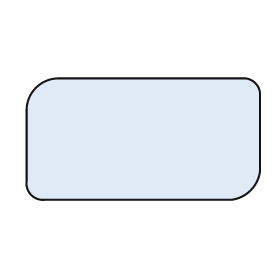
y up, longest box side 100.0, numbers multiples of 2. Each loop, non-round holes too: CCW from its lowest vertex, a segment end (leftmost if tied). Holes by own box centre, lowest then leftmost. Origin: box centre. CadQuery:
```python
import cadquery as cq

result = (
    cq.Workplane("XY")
    .moveTo(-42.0, -26.0)
    .lineTo(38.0, -26.0)
    .threePointArc((46.0, -22.0), (50.0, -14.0))
    .lineTo(50.0, 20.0)
    .threePointArc((48.0, 24.0), (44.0, 26.0))
    .lineTo(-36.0, 26.0)
    .threePointArc((-46.0, 22.0), (-50.0, 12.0))
    .lineTo(-50.0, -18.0)
    .threePointArc((-48.0, -24.0), (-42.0, -26.0))
    .close()
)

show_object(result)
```